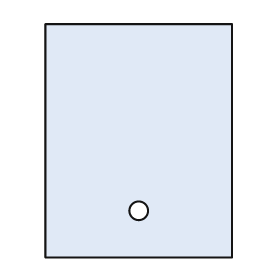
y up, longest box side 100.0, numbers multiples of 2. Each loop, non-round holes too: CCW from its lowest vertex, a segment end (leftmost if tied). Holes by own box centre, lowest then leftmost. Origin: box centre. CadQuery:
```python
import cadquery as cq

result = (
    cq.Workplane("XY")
    .moveTo(-40.0, -50.0)
    .lineTo(40.0, -50.0)
    .lineTo(40.0, 50.0)
    .lineTo(-40.0, 50.0)
    .close()
    .moveTo(0.0, -30.0)
    .circle(4.0)
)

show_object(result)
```